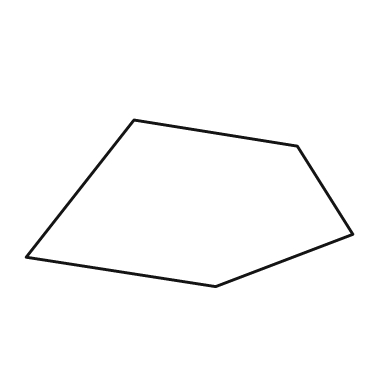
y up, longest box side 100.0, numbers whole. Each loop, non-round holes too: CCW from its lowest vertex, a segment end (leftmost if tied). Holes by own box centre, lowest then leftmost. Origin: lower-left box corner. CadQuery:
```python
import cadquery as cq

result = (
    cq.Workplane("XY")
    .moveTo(58.0, 0.0)
    .lineTo(100.0, 16.0)
    .lineTo(83.0, 43.0)
    .lineTo(33.0, 51.0)
    .lineTo(0.0, 9.0)
    .close()
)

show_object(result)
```